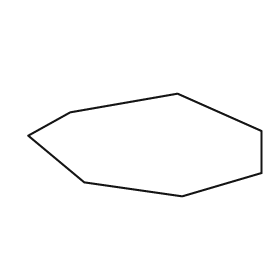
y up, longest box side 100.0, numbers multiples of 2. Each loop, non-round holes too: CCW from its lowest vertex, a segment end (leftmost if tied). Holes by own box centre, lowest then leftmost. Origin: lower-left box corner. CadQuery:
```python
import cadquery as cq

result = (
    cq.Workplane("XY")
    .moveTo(66.0, 0.0)
    .lineTo(100.0, 10.0)
    .lineTo(100.0, 28.0)
    .lineTo(64.0, 44.0)
    .lineTo(18.0, 36.0)
    .lineTo(0.0, 26.0)
    .lineTo(24.0, 6.0)
    .close()
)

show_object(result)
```